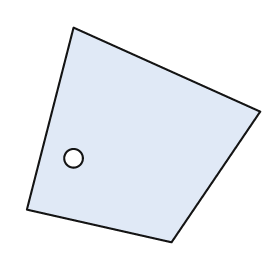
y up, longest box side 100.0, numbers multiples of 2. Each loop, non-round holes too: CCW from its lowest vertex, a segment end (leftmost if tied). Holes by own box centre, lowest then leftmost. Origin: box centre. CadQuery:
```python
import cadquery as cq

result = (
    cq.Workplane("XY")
    .moveTo(12.0, -46.0)
    .lineTo(50.0, 10.0)
    .lineTo(-30.0, 46.0)
    .lineTo(-50.0, -32.0)
    .close()
    .moveTo(-30.0, -10.0)
    .circle(4.0)
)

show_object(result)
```